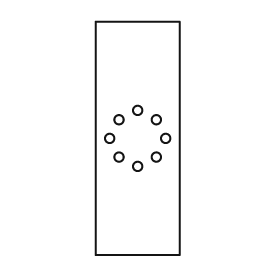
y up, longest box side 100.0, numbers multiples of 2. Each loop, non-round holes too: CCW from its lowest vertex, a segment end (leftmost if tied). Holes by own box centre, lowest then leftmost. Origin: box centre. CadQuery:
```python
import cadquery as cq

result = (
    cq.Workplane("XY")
    .moveTo(-18.0, -50.0)
    .lineTo(18.0, -50.0)
    .lineTo(18.0, 50.0)
    .lineTo(-18.0, 50.0)
    .close()
    .moveTo(0.0, -12.0)
    .circle(2.0)
    .moveTo(-8.0, -8.0)
    .circle(2.0)
    .moveTo(8.0, -8.0)
    .circle(2.0)
    .moveTo(-12.0, 0.0)
    .circle(2.0)
    .moveTo(12.0, 0.0)
    .circle(2.0)
    .moveTo(-8.0, 8.0)
    .circle(2.0)
    .moveTo(8.0, 8.0)
    .circle(2.0)
    .moveTo(0.0, 12.0)
    .circle(2.0)
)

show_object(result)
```